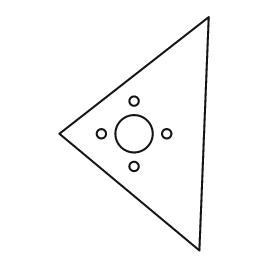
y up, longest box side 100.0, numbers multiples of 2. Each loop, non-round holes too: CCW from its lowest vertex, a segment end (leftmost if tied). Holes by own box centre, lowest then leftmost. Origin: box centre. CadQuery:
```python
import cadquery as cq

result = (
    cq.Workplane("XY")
    .moveTo(28.0, -50.0)
    .lineTo(32.0, 50.0)
    .lineTo(-32.0, 0.0)
    .close()
    .moveTo(0.0, -14.0)
    .circle(2.0)
    .moveTo(-14.0, 0.0)
    .circle(2.0)
    .moveTo(0.0, 0.0)
    .circle(8.0)
    .moveTo(14.0, 0.0)
    .circle(2.0)
    .moveTo(0.0, 14.0)
    .circle(2.0)
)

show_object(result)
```